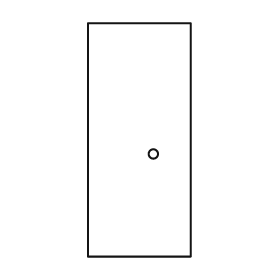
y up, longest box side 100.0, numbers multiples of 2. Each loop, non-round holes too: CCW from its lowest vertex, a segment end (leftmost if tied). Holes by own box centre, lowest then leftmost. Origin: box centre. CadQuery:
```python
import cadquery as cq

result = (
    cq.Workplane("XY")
    .moveTo(-22.0, -50.0)
    .lineTo(22.0, -50.0)
    .lineTo(22.0, 50.0)
    .lineTo(-22.0, 50.0)
    .close()
    .moveTo(6.0, -6.0)
    .circle(2.0)
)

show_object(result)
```